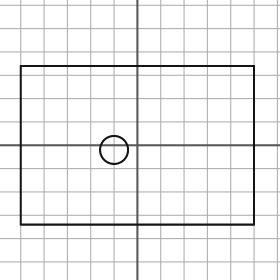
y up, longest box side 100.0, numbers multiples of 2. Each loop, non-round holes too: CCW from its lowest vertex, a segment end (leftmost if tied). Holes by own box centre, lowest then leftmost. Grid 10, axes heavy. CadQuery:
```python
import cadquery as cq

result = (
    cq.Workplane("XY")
    .moveTo(-50.0, -34.0)
    .lineTo(50.0, -34.0)
    .lineTo(50.0, 34.0)
    .lineTo(-50.0, 34.0)
    .close()
    .moveTo(-10.0, -2.0)
    .circle(6.0)
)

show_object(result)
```